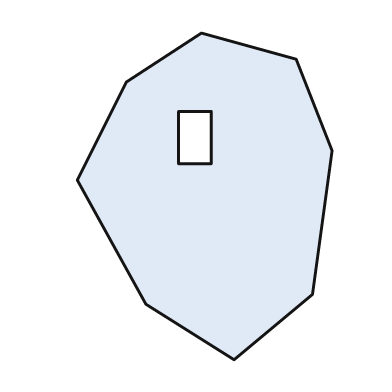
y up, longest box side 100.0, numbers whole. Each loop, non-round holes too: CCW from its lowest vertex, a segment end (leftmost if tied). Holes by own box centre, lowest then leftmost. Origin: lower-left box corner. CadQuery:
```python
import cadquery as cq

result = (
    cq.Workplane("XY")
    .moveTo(48.0, 0.0)
    .lineTo(72.0, 20.0)
    .lineTo(78.0, 64.0)
    .lineTo(67.0, 92.0)
    .lineTo(38.0, 100.0)
    .lineTo(15.0, 85.0)
    .lineTo(0.0, 55.0)
    .lineTo(21.0, 17.0)
    .close()
    .moveTo(31.0, 60.0)
    .lineTo(41.0, 60.0)
    .lineTo(41.0, 76.0)
    .lineTo(31.0, 76.0)
    .close()
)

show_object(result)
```